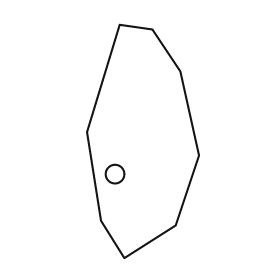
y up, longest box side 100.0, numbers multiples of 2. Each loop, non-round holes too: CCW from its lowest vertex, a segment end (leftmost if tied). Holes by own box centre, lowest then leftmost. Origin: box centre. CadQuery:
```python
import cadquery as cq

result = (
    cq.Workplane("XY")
    .moveTo(-8.0, -50.0)
    .lineTo(14.0, -36.0)
    .lineTo(24.0, -6.0)
    .lineTo(16.0, 30.0)
    .lineTo(4.0, 48.0)
    .lineTo(-10.0, 50.0)
    .lineTo(-24.0, 4.0)
    .lineTo(-18.0, -34.0)
    .close()
    .moveTo(-12.0, -14.0)
    .circle(4.0)
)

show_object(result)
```